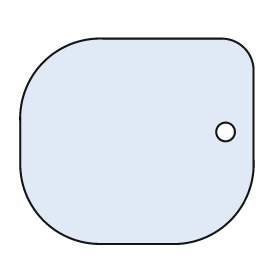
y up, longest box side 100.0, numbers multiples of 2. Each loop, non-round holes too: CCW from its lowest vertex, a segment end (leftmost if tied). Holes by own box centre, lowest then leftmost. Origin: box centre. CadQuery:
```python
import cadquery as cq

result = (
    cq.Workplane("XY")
    .moveTo(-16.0, -44.0)
    .lineTo(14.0, -44.0)
    .threePointArc((40.0, -34.0), (50.0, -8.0))
    .lineTo(50.0, 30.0)
    .threePointArc((46.0, 40.0), (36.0, 44.0))
    .lineTo(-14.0, 44.0)
    .threePointArc((-40.0, 34.0), (-50.0, 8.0))
    .lineTo(-50.0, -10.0)
    .threePointArc((-40.0, -34.0), (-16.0, -44.0))
    .close()
    .moveTo(38.0, 4.0)
    .circle(4.0)
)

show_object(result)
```